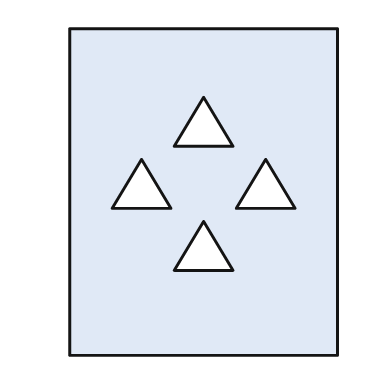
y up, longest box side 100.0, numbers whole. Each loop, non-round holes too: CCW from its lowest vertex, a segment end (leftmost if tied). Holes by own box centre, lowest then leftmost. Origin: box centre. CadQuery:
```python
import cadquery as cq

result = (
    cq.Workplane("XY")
    .moveTo(-41.0, -50.0)
    .lineTo(41.0, -50.0)
    .lineTo(41.0, 50.0)
    .lineTo(-41.0, 50.0)
    .close()
    .moveTo(-9.0, -24.0)
    .lineTo(9.0, -24.0)
    .lineTo(0.0, -9.0)
    .close()
    .moveTo(-28.0, -5.0)
    .lineTo(-10.0, -5.0)
    .lineTo(-19.0, 10.0)
    .close()
    .moveTo(10.0, -5.0)
    .lineTo(28.0, -5.0)
    .lineTo(19.0, 10.0)
    .close()
    .moveTo(-9.0, 14.0)
    .lineTo(9.0, 14.0)
    .lineTo(0.0, 29.0)
    .close()
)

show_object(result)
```